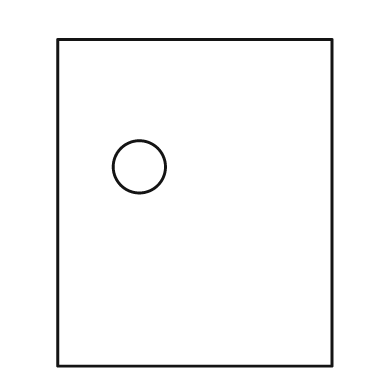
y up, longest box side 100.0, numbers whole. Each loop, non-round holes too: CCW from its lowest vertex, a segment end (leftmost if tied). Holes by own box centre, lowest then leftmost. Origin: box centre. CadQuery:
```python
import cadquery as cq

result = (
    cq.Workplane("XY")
    .moveTo(-42.0, -50.0)
    .lineTo(42.0, -50.0)
    .lineTo(42.0, 50.0)
    .lineTo(-42.0, 50.0)
    .close()
    .moveTo(-17.0, 11.0)
    .circle(8.0)
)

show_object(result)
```